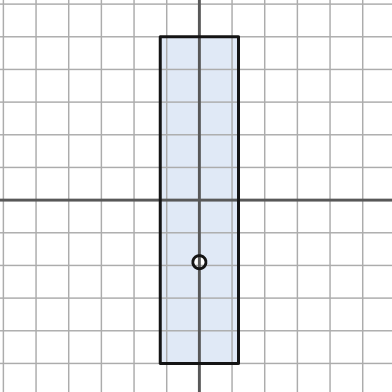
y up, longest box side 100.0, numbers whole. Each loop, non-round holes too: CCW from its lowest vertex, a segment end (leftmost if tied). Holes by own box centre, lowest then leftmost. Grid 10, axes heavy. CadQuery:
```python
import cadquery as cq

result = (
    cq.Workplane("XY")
    .moveTo(-12.0, -50.0)
    .lineTo(12.0, -50.0)
    .lineTo(12.0, 50.0)
    .lineTo(-12.0, 50.0)
    .close()
    .moveTo(0.0, -19.0)
    .circle(2.0)
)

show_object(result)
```